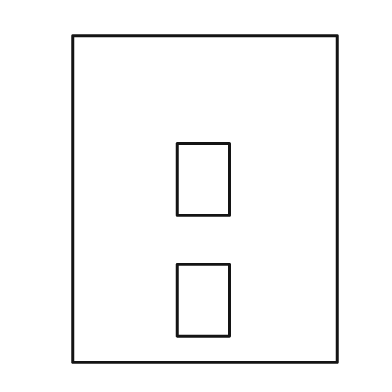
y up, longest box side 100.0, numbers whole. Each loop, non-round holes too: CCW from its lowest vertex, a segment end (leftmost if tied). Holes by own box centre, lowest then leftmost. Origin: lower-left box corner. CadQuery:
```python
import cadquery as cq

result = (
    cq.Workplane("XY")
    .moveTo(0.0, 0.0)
    .lineTo(81.0, 0.0)
    .lineTo(81.0, 100.0)
    .lineTo(0.0, 100.0)
    .close()
    .moveTo(32.0, 8.0)
    .lineTo(48.0, 8.0)
    .lineTo(48.0, 30.0)
    .lineTo(32.0, 30.0)
    .close()
    .moveTo(32.0, 45.0)
    .lineTo(48.0, 45.0)
    .lineTo(48.0, 67.0)
    .lineTo(32.0, 67.0)
    .close()
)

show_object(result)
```